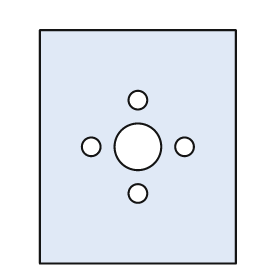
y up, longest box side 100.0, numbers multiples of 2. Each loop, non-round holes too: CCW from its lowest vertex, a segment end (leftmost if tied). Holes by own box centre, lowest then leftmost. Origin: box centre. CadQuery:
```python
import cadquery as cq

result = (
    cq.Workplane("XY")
    .moveTo(-42.0, -50.0)
    .lineTo(42.0, -50.0)
    .lineTo(42.0, 50.0)
    .lineTo(-42.0, 50.0)
    .close()
    .moveTo(0.0, -20.0)
    .circle(4.0)
    .moveTo(-20.0, 0.0)
    .circle(4.0)
    .moveTo(0.0, 0.0)
    .circle(10.0)
    .moveTo(20.0, 0.0)
    .circle(4.0)
    .moveTo(0.0, 20.0)
    .circle(4.0)
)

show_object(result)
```